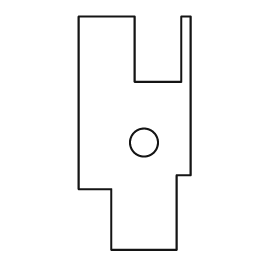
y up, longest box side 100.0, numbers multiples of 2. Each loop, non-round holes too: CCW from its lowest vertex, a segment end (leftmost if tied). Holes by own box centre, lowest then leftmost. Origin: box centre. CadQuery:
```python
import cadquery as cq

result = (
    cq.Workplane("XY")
    .moveTo(-10.0, -50.0)
    .lineTo(18.0, -50.0)
    .lineTo(18.0, -18.0)
    .lineTo(24.0, -18.0)
    .lineTo(24.0, 50.0)
    .lineTo(20.0, 50.0)
    .lineTo(20.0, 22.0)
    .lineTo(0.0, 22.0)
    .lineTo(0.0, 50.0)
    .lineTo(-24.0, 50.0)
    .lineTo(-24.0, -24.0)
    .lineTo(-10.0, -24.0)
    .close()
    .moveTo(4.0, -4.0)
    .circle(6.0)
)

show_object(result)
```